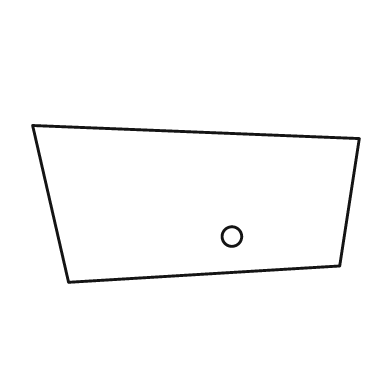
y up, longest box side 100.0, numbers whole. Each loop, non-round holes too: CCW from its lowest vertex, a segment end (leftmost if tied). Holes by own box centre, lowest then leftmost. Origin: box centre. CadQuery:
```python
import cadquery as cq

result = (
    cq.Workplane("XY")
    .moveTo(-39.0, -24.0)
    .lineTo(44.0, -19.0)
    .lineTo(50.0, 20.0)
    .lineTo(-50.0, 24.0)
    .close()
    .moveTo(11.0, -10.0)
    .circle(3.0)
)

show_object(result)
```